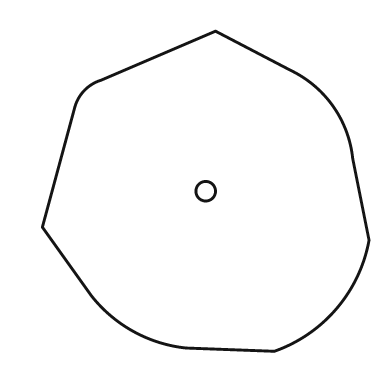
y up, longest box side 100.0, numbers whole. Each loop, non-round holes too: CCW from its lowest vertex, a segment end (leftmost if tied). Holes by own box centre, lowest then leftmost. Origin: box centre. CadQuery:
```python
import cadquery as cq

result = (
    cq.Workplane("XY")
    .moveTo(21.0, -49.0)
    .threePointArc((40.0, -36.0), (50.0, -15.0))
    .lineTo(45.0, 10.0)
    .threePointArc((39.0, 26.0), (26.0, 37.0))
    .lineTo(3.0, 49.0)
    .lineTo(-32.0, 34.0)
    .threePointArc((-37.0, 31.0), (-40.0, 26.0))
    .lineTo(-50.0, -11.0)
    .lineTo(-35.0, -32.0)
    .threePointArc((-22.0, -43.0), (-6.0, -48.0))
    .close()
    .moveTo(0.0, 0.0)
    .circle(3.0)
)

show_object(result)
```